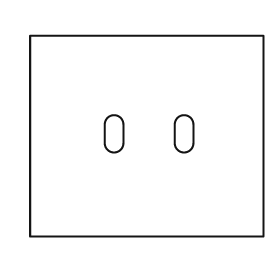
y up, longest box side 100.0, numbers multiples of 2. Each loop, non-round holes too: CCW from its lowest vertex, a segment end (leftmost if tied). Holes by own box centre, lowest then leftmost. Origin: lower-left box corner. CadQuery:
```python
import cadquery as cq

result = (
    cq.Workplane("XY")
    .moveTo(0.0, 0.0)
    .lineTo(100.0, 0.0)
    .lineTo(100.0, 86.0)
    .lineTo(0.0, 86.0)
    .close()
    .moveTo(32.0, 40.0)
    .threePointArc((36.0, 36.0), (40.0, 40.0))
    .lineTo(40.0, 48.0)
    .threePointArc((36.0, 52.0), (32.0, 48.0))
    .close()
    .moveTo(62.0, 40.0)
    .threePointArc((66.0, 36.0), (70.0, 40.0))
    .lineTo(70.0, 48.0)
    .threePointArc((66.0, 52.0), (62.0, 48.0))
    .close()
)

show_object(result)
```